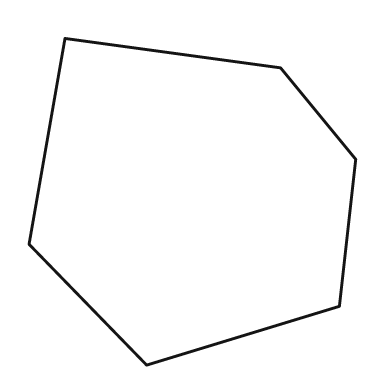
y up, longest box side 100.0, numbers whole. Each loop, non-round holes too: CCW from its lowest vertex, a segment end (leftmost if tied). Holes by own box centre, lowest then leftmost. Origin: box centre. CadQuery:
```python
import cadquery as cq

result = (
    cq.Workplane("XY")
    .moveTo(-14.0, -50.0)
    .lineTo(45.0, -32.0)
    .lineTo(50.0, 13.0)
    .lineTo(27.0, 41.0)
    .lineTo(-39.0, 50.0)
    .lineTo(-50.0, -13.0)
    .close()
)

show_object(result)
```